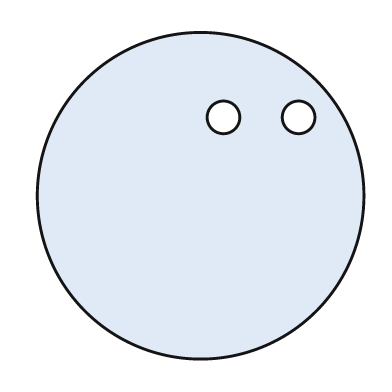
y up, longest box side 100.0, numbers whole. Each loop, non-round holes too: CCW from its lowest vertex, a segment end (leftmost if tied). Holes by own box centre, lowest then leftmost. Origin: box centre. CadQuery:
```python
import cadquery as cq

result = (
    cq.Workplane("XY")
    .moveTo(0.0, 0.0)
    .circle(50.0)
    .moveTo(7.0, 24.0)
    .circle(5.0)
    .moveTo(30.0, 24.0)
    .circle(5.0)
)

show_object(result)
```